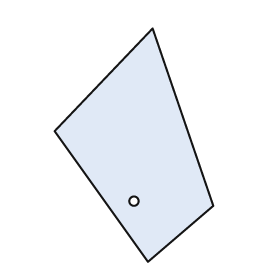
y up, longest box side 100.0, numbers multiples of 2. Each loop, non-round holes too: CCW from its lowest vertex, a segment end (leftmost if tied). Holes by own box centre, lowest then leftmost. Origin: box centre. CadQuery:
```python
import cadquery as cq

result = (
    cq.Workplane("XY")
    .moveTo(6.0, -50.0)
    .lineTo(34.0, -26.0)
    .lineTo(8.0, 50.0)
    .lineTo(-34.0, 6.0)
    .close()
    .moveTo(0.0, -24.0)
    .circle(2.0)
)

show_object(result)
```